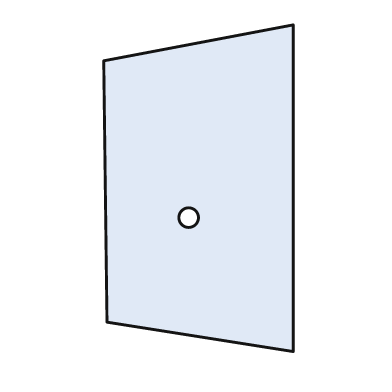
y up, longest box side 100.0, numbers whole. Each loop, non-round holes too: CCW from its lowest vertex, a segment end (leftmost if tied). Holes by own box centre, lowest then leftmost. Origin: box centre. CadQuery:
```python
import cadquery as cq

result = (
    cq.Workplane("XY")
    .moveTo(29.0, -50.0)
    .lineTo(29.0, 50.0)
    .lineTo(-29.0, 39.0)
    .lineTo(-28.0, -41.0)
    .close()
    .moveTo(-3.0, -9.0)
    .circle(3.0)
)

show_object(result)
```